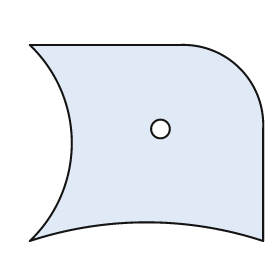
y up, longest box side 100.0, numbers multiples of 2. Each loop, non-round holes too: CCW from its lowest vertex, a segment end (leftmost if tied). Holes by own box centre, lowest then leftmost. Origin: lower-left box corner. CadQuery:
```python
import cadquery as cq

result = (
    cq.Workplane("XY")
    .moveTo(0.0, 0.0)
    .threePointArc((50.0, 8.0), (100.0, 0.0))
    .lineTo(100.0, 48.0)
    .threePointArc((90.0, 74.0), (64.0, 84.0))
    .lineTo(0.0, 84.0)
    .threePointArc((18.0, 42.0), (0.0, 0.0))
    .close()
    .moveTo(56.0, 48.0)
    .circle(4.0)
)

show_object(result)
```